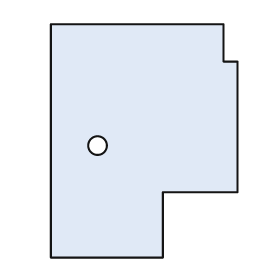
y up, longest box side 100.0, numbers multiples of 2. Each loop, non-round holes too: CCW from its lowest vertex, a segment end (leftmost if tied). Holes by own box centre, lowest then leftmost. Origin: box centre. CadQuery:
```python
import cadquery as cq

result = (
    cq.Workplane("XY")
    .moveTo(-40.0, -50.0)
    .lineTo(8.0, -50.0)
    .lineTo(8.0, -22.0)
    .lineTo(40.0, -22.0)
    .lineTo(40.0, 34.0)
    .lineTo(34.0, 34.0)
    .lineTo(34.0, 50.0)
    .lineTo(-40.0, 50.0)
    .close()
    .moveTo(-20.0, -2.0)
    .circle(4.0)
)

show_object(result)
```